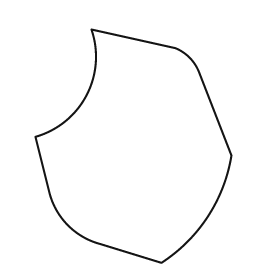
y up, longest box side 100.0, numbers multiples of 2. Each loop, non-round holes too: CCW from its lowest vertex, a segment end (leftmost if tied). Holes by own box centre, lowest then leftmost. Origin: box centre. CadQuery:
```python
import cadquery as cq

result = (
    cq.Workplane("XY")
    .moveTo(12.0, -50.0)
    .threePointArc((32.0, -30.0), (42.0, -4.0))
    .lineTo(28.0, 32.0)
    .threePointArc((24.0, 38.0), (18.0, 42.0))
    .lineTo(-18.0, 50.0)
    .threePointArc((-20.0, 22.0), (-42.0, 4.0))
    .lineTo(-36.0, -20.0)
    .threePointArc((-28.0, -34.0), (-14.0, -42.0))
    .close()
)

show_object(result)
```